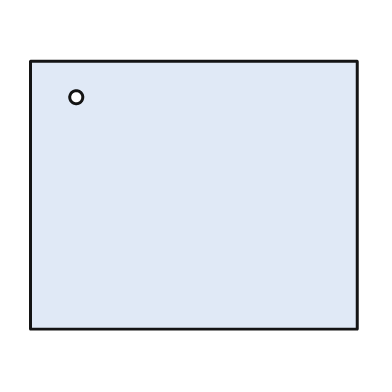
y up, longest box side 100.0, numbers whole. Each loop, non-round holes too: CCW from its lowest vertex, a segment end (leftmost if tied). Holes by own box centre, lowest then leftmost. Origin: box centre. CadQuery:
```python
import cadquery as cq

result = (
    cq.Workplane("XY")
    .moveTo(-50.0, -41.0)
    .lineTo(50.0, -41.0)
    .lineTo(50.0, 41.0)
    .lineTo(-50.0, 41.0)
    .close()
    .moveTo(-36.0, 30.0)
    .circle(2.0)
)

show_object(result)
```